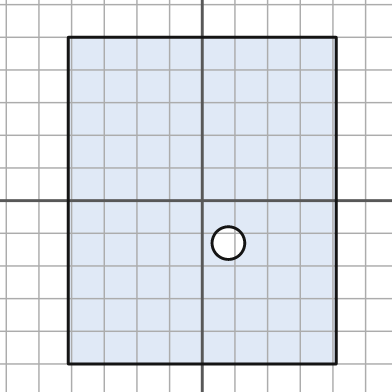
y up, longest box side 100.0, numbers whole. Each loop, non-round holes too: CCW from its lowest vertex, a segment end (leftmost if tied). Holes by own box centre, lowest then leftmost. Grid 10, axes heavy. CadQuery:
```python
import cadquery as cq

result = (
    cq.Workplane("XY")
    .moveTo(-41.0, -50.0)
    .lineTo(41.0, -50.0)
    .lineTo(41.0, 50.0)
    .lineTo(-41.0, 50.0)
    .close()
    .moveTo(8.0, -13.0)
    .circle(5.0)
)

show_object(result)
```